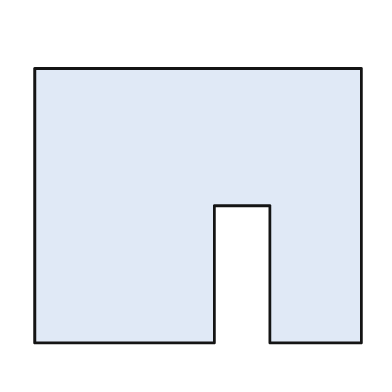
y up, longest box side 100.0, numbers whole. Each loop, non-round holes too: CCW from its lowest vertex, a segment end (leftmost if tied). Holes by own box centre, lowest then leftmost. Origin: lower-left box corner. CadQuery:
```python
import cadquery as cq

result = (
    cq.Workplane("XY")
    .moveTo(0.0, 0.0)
    .lineTo(55.0, 0.0)
    .lineTo(55.0, 42.0)
    .lineTo(72.0, 42.0)
    .lineTo(72.0, 0.0)
    .lineTo(100.0, 0.0)
    .lineTo(100.0, 84.0)
    .lineTo(0.0, 84.0)
    .close()
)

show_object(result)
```